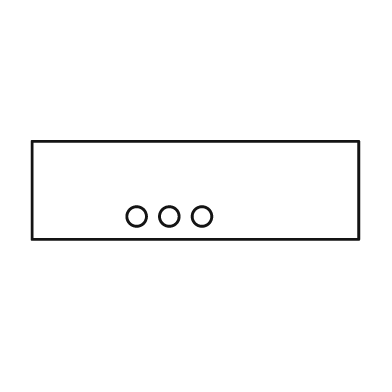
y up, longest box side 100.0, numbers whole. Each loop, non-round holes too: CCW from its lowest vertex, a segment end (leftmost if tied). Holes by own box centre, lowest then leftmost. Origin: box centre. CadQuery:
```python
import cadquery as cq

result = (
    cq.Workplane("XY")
    .moveTo(-50.0, -15.0)
    .lineTo(50.0, -15.0)
    .lineTo(50.0, 15.0)
    .lineTo(-50.0, 15.0)
    .close()
    .moveTo(-18.0, -8.0)
    .circle(3.0)
    .moveTo(-8.0, -8.0)
    .circle(3.0)
    .moveTo(2.0, -8.0)
    .circle(3.0)
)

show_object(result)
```